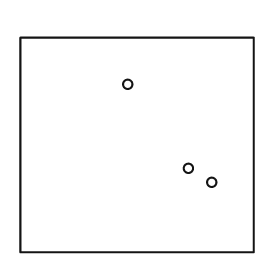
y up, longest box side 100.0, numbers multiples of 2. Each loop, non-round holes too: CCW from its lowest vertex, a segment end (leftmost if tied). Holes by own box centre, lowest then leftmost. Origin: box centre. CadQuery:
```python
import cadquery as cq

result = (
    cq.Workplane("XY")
    .moveTo(-50.0, -46.0)
    .lineTo(50.0, -46.0)
    .lineTo(50.0, 46.0)
    .lineTo(-50.0, 46.0)
    .close()
    .moveTo(32.0, -16.0)
    .circle(2.0)
    .moveTo(22.0, -10.0)
    .circle(2.0)
    .moveTo(-4.0, 26.0)
    .circle(2.0)
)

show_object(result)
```